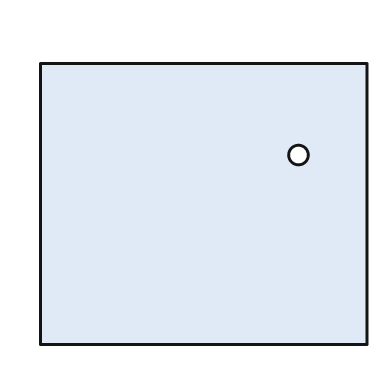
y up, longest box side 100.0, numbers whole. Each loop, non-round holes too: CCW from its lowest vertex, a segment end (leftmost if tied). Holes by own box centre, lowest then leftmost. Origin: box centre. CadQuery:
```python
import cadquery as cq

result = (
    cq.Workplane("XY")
    .moveTo(-50.0, -43.0)
    .lineTo(50.0, -43.0)
    .lineTo(50.0, 43.0)
    .lineTo(-50.0, 43.0)
    .close()
    .moveTo(29.0, 15.0)
    .circle(3.0)
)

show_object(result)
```